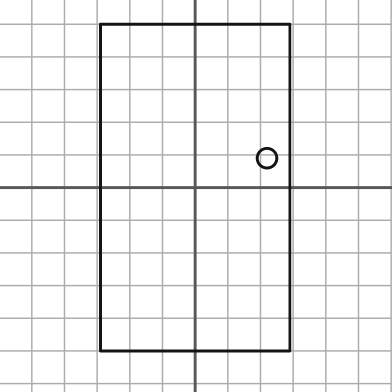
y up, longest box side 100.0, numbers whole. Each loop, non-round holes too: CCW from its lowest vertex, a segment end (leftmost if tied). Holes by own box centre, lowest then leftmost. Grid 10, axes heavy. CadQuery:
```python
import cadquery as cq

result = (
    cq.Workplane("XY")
    .moveTo(-29.0, -50.0)
    .lineTo(29.0, -50.0)
    .lineTo(29.0, 50.0)
    .lineTo(-29.0, 50.0)
    .close()
    .moveTo(22.0, 9.0)
    .circle(3.0)
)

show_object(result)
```